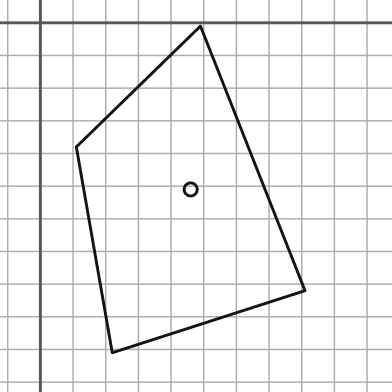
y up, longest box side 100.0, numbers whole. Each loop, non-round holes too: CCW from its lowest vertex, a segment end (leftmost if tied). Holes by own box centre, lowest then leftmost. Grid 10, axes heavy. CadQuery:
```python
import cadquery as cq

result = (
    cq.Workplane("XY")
    .moveTo(22.0, -101.0)
    .lineTo(81.0, -82.0)
    .lineTo(49.0, -1.0)
    .lineTo(11.0, -38.0)
    .close()
    .moveTo(46.0, -51.0)
    .circle(2.0)
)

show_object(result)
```